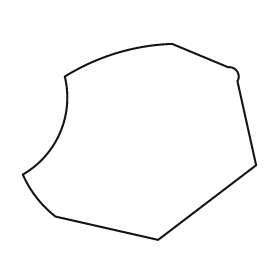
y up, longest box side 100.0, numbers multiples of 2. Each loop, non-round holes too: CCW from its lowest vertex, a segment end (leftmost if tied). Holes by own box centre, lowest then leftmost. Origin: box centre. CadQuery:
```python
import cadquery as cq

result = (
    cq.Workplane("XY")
    .moveTo(8.0, -42.0)
    .lineTo(50.0, -10.0)
    .lineTo(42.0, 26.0)
    .threePointArc((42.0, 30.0), (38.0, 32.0))
    .lineTo(14.0, 42.0)
    .threePointArc((-10.0, 38.0), (-32.0, 28.0))
    .threePointArc((-34.0, 4.0), (-50.0, -14.0))
    .threePointArc((-44.0, -24.0), (-36.0, -32.0))
    .close()
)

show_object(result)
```